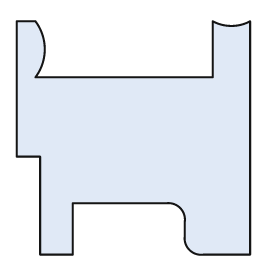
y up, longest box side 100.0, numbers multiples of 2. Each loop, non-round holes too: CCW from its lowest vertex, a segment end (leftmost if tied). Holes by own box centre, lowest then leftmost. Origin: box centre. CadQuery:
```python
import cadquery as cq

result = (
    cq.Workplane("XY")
    .moveTo(-40.0, -50.0)
    .lineTo(-26.0, -50.0)
    .lineTo(-26.0, -28.0)
    .lineTo(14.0, -28.0)
    .threePointArc((20.0, -30.0), (22.0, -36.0))
    .lineTo(22.0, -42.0)
    .threePointArc((24.0, -48.0), (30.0, -50.0))
    .lineTo(50.0, -50.0)
    .lineTo(50.0, 50.0)
    .threePointArc((42.0, 48.0), (34.0, 50.0))
    .lineTo(34.0, 26.0)
    .lineTo(-42.0, 26.0)
    .threePointArc((-38.0, 38.0), (-42.0, 50.0))
    .lineTo(-50.0, 50.0)
    .lineTo(-50.0, -8.0)
    .lineTo(-40.0, -8.0)
    .close()
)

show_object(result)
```